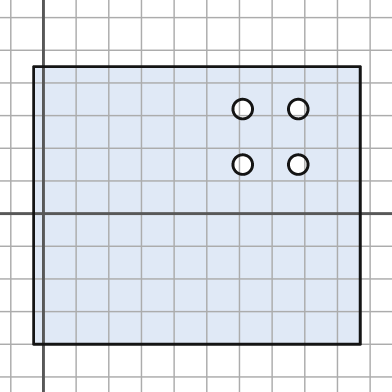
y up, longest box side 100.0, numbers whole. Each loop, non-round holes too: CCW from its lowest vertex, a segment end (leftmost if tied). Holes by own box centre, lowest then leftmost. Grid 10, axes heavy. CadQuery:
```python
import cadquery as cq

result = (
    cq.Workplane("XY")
    .moveTo(-3.0, -40.0)
    .lineTo(97.0, -40.0)
    .lineTo(97.0, 45.0)
    .lineTo(-3.0, 45.0)
    .close()
    .moveTo(61.0, 15.0)
    .circle(3.0)
    .moveTo(78.0, 15.0)
    .circle(3.0)
    .moveTo(61.0, 32.0)
    .circle(3.0)
    .moveTo(78.0, 32.0)
    .circle(3.0)
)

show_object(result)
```